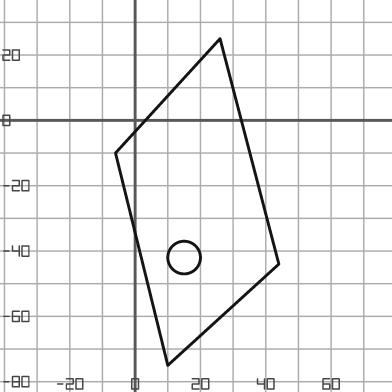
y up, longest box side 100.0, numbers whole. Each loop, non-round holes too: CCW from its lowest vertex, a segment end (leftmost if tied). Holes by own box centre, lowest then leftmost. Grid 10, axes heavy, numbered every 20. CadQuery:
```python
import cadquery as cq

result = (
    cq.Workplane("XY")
    .moveTo(10.0, -75.0)
    .lineTo(44.0, -44.0)
    .lineTo(26.0, 25.0)
    .lineTo(-6.0, -10.0)
    .close()
    .moveTo(15.0, -42.0)
    .circle(5.0)
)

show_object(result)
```